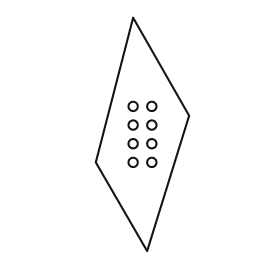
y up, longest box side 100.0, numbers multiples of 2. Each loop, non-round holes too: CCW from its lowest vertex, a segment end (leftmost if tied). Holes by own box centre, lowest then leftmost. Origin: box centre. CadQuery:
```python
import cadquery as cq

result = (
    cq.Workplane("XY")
    .moveTo(2.0, -50.0)
    .lineTo(20.0, 8.0)
    .lineTo(-4.0, 50.0)
    .lineTo(-20.0, -12.0)
    .close()
    .moveTo(-4.0, -12.0)
    .circle(2.0)
    .moveTo(4.0, -12.0)
    .circle(2.0)
    .moveTo(-4.0, -4.0)
    .circle(2.0)
    .moveTo(4.0, -4.0)
    .circle(2.0)
    .moveTo(-4.0, 4.0)
    .circle(2.0)
    .moveTo(4.0, 4.0)
    .circle(2.0)
    .moveTo(-4.0, 12.0)
    .circle(2.0)
    .moveTo(4.0, 12.0)
    .circle(2.0)
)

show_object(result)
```